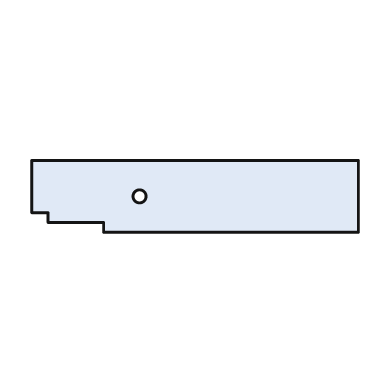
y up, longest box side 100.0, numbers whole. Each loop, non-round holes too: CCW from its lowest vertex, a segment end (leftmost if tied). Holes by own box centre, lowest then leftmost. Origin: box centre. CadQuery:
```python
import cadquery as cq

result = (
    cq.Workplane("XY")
    .moveTo(-28.0, -11.0)
    .lineTo(50.0, -11.0)
    .lineTo(50.0, 11.0)
    .lineTo(-50.0, 11.0)
    .lineTo(-50.0, -5.0)
    .lineTo(-45.0, -5.0)
    .lineTo(-45.0, -8.0)
    .lineTo(-28.0, -8.0)
    .close()
    .moveTo(-17.0, 0.0)
    .circle(2.0)
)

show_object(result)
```